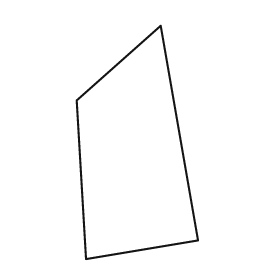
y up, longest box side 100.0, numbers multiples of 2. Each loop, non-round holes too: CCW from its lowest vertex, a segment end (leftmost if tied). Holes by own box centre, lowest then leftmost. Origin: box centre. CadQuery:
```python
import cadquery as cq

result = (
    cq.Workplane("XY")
    .moveTo(-22.0, -50.0)
    .lineTo(26.0, -42.0)
    .lineTo(10.0, 50.0)
    .lineTo(-26.0, 18.0)
    .close()
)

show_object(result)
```